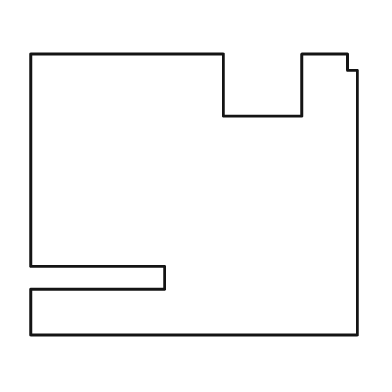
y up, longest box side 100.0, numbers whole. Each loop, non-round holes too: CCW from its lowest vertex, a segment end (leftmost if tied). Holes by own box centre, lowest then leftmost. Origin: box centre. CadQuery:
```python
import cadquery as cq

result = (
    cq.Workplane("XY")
    .moveTo(-50.0, -43.0)
    .lineTo(50.0, -43.0)
    .lineTo(50.0, 38.0)
    .lineTo(47.0, 38.0)
    .lineTo(47.0, 43.0)
    .lineTo(33.0, 43.0)
    .lineTo(33.0, 24.0)
    .lineTo(9.0, 24.0)
    .lineTo(9.0, 43.0)
    .lineTo(-50.0, 43.0)
    .lineTo(-50.0, -22.0)
    .lineTo(-9.0, -22.0)
    .lineTo(-9.0, -29.0)
    .lineTo(-50.0, -29.0)
    .close()
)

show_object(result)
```